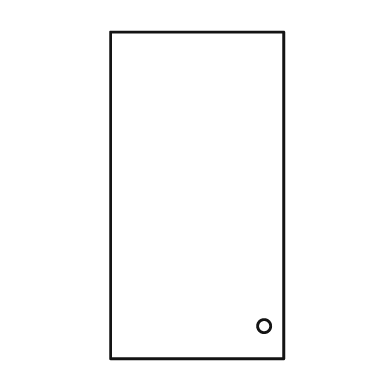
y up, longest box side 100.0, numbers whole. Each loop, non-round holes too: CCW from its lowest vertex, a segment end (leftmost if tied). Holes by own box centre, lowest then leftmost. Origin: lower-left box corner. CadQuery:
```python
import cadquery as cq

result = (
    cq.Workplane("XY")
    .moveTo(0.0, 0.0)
    .lineTo(53.0, 0.0)
    .lineTo(53.0, 100.0)
    .lineTo(0.0, 100.0)
    .close()
    .moveTo(47.0, 10.0)
    .circle(2.0)
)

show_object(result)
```